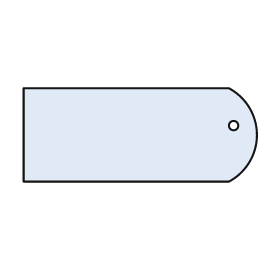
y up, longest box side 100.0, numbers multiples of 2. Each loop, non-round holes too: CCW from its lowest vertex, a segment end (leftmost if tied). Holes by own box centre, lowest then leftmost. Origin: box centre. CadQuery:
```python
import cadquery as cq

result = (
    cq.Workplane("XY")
    .moveTo(-50.0, -20.0)
    .lineTo(38.0, -20.0)
    .threePointArc((50.0, 0.0), (38.0, 20.0))
    .lineTo(-50.0, 20.0)
    .close()
    .moveTo(40.0, 4.0)
    .circle(2.0)
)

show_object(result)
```